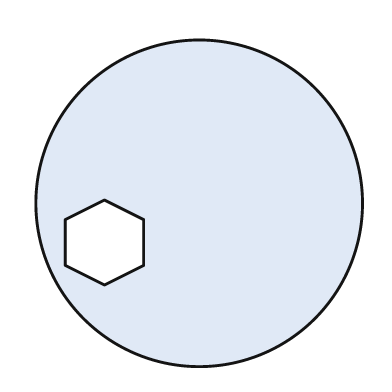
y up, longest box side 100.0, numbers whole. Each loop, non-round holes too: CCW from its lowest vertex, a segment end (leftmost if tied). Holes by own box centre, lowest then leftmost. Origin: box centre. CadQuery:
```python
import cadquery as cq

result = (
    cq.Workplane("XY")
    .moveTo(0.0, 0.0)
    .circle(50.0)
    .moveTo(-29.0, -25.0)
    .lineTo(-17.0, -19.0)
    .lineTo(-17.0, -5.0)
    .lineTo(-29.0, 1.0)
    .lineTo(-41.0, -5.0)
    .lineTo(-41.0, -19.0)
    .close()
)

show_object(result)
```